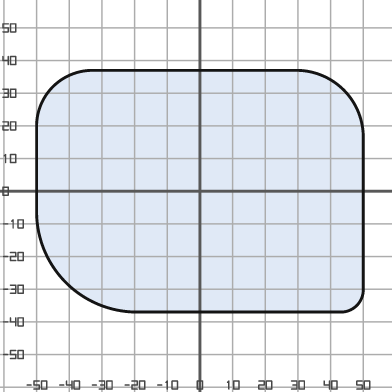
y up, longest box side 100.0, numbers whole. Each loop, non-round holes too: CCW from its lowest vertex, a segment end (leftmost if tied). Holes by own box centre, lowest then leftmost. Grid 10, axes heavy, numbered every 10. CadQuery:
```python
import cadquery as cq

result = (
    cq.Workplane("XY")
    .moveTo(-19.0, -37.0)
    .lineTo(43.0, -37.0)
    .threePointArc((48.0, -35.0), (50.0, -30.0))
    .lineTo(50.0, 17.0)
    .threePointArc((44.0, 31.0), (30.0, 37.0))
    .lineTo(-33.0, 37.0)
    .threePointArc((-45.0, 32.0), (-50.0, 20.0))
    .lineTo(-50.0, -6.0)
    .threePointArc((-41.0, -28.0), (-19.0, -37.0))
    .close()
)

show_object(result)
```